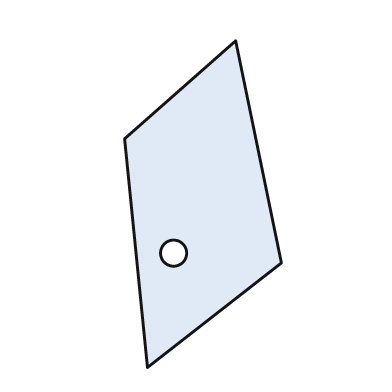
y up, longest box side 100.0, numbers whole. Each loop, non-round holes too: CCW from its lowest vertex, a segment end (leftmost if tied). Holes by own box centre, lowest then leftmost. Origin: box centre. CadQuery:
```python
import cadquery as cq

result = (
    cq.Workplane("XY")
    .moveTo(-17.0, -50.0)
    .lineTo(24.0, -18.0)
    .lineTo(10.0, 50.0)
    .lineTo(-24.0, 20.0)
    .close()
    .moveTo(-9.0, -15.0)
    .circle(4.0)
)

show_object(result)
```